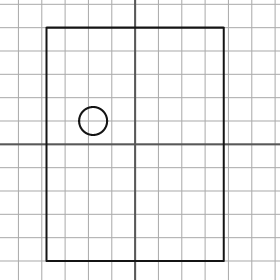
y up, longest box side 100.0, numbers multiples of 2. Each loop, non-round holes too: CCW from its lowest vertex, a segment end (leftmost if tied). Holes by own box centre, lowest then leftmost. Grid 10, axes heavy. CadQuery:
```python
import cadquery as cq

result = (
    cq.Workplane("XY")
    .moveTo(-38.0, -50.0)
    .lineTo(38.0, -50.0)
    .lineTo(38.0, 50.0)
    .lineTo(-38.0, 50.0)
    .close()
    .moveTo(-18.0, 10.0)
    .circle(6.0)
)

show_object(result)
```